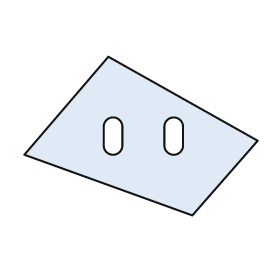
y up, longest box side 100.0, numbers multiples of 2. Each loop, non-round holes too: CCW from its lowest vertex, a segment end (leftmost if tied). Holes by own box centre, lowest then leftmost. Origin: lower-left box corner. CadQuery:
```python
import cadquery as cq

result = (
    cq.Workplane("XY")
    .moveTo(72.0, 0.0)
    .lineTo(100.0, 32.0)
    .lineTo(36.0, 68.0)
    .lineTo(0.0, 26.0)
    .close()
    .moveTo(34.0, 30.0)
    .threePointArc((38.0, 26.0), (42.0, 30.0))
    .lineTo(42.0, 38.0)
    .threePointArc((38.0, 42.0), (34.0, 38.0))
    .close()
    .moveTo(60.0, 30.0)
    .threePointArc((64.0, 26.0), (68.0, 30.0))
    .lineTo(68.0, 38.0)
    .threePointArc((64.0, 42.0), (60.0, 38.0))
    .close()
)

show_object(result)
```